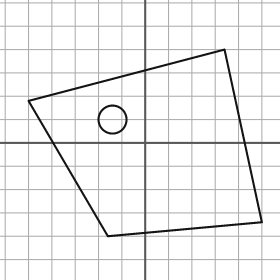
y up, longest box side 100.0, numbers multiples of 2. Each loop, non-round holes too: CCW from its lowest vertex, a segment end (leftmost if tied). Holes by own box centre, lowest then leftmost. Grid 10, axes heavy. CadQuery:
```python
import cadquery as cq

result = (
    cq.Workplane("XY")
    .moveTo(-16.0, -40.0)
    .lineTo(50.0, -34.0)
    .lineTo(34.0, 40.0)
    .lineTo(-50.0, 18.0)
    .close()
    .moveTo(-14.0, 10.0)
    .circle(6.0)
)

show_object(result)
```